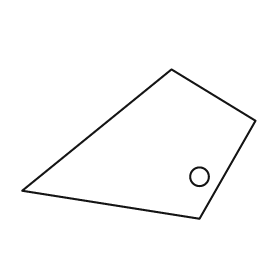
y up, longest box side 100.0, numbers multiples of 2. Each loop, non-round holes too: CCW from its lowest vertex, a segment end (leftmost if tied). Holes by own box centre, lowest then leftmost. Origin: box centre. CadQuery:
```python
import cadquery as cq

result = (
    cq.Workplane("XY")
    .moveTo(26.0, -32.0)
    .lineTo(50.0, 10.0)
    .lineTo(14.0, 32.0)
    .lineTo(-50.0, -20.0)
    .close()
    .moveTo(26.0, -14.0)
    .circle(4.0)
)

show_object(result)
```